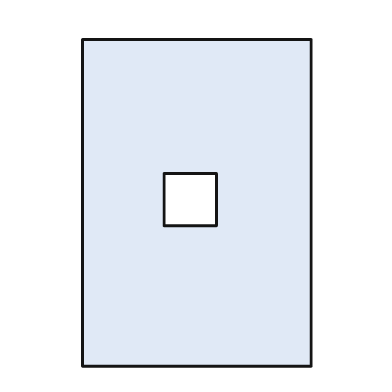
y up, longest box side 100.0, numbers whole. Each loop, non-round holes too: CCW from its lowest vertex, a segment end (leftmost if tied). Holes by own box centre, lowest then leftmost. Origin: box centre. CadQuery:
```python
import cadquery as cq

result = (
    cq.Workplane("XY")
    .moveTo(-35.0, -50.0)
    .lineTo(35.0, -50.0)
    .lineTo(35.0, 50.0)
    .lineTo(-35.0, 50.0)
    .close()
    .moveTo(-10.0, -7.0)
    .lineTo(6.0, -7.0)
    .lineTo(6.0, 9.0)
    .lineTo(-10.0, 9.0)
    .close()
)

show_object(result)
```